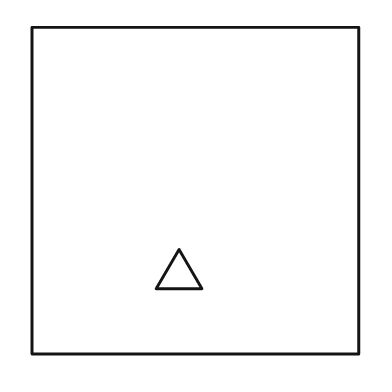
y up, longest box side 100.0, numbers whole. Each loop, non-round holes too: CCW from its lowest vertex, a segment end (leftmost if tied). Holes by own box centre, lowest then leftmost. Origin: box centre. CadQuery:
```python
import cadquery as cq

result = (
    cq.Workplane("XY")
    .moveTo(-50.0, -50.0)
    .lineTo(50.0, -50.0)
    .lineTo(50.0, 50.0)
    .lineTo(-50.0, 50.0)
    .close()
    .moveTo(-12.0, -30.0)
    .lineTo(2.0, -30.0)
    .lineTo(-5.0, -18.0)
    .close()
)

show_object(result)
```